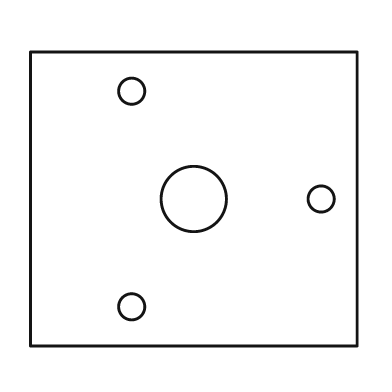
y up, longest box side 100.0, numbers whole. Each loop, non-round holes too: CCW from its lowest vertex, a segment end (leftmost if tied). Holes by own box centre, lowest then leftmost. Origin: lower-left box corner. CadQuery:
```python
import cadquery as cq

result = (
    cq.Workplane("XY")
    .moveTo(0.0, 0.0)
    .lineTo(100.0, 0.0)
    .lineTo(100.0, 90.0)
    .lineTo(0.0, 90.0)
    .close()
    .moveTo(31.0, 12.0)
    .circle(4.0)
    .moveTo(50.0, 45.0)
    .circle(10.0)
    .moveTo(89.0, 45.0)
    .circle(4.0)
    .moveTo(31.0, 78.0)
    .circle(4.0)
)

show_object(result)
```